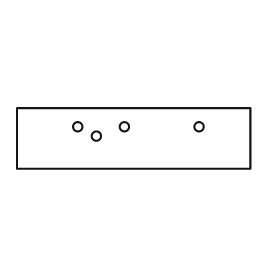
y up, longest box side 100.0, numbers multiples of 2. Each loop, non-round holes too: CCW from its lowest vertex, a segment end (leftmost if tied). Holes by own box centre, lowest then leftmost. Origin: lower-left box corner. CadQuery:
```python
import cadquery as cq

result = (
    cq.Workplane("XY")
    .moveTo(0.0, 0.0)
    .lineTo(100.0, 0.0)
    .lineTo(100.0, 26.0)
    .lineTo(0.0, 26.0)
    .close()
    .moveTo(34.0, 14.0)
    .circle(2.0)
    .moveTo(26.0, 18.0)
    .circle(2.0)
    .moveTo(46.0, 18.0)
    .circle(2.0)
    .moveTo(78.0, 18.0)
    .circle(2.0)
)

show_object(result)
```